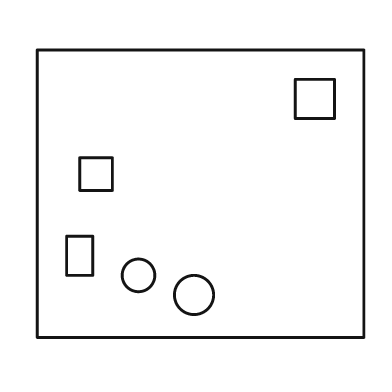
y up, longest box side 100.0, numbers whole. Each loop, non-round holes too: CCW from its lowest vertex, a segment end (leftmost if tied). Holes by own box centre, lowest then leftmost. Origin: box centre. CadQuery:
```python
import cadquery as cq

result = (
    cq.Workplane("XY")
    .moveTo(-50.0, -44.0)
    .lineTo(50.0, -44.0)
    .lineTo(50.0, 44.0)
    .lineTo(-50.0, 44.0)
    .close()
    .moveTo(-2.0, -31.0)
    .circle(6.0)
    .moveTo(-19.0, -25.0)
    .circle(5.0)
    .moveTo(-41.0, -25.0)
    .lineTo(-33.0, -25.0)
    .lineTo(-33.0, -13.0)
    .lineTo(-41.0, -13.0)
    .close()
    .moveTo(-37.0, 1.0)
    .lineTo(-27.0, 1.0)
    .lineTo(-27.0, 11.0)
    .lineTo(-37.0, 11.0)
    .close()
    .moveTo(29.0, 23.0)
    .lineTo(41.0, 23.0)
    .lineTo(41.0, 35.0)
    .lineTo(29.0, 35.0)
    .close()
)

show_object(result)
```